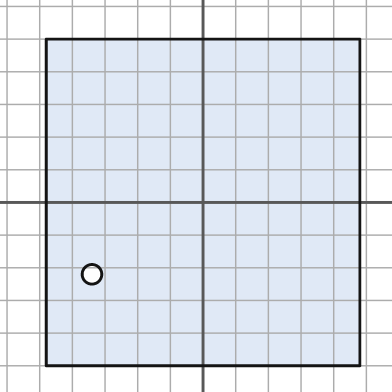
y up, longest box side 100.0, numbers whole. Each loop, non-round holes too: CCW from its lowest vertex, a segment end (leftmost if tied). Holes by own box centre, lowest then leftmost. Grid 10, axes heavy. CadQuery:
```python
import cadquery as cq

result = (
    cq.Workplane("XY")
    .moveTo(-48.0, -50.0)
    .lineTo(48.0, -50.0)
    .lineTo(48.0, 50.0)
    .lineTo(-48.0, 50.0)
    .close()
    .moveTo(-34.0, -22.0)
    .circle(3.0)
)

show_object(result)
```